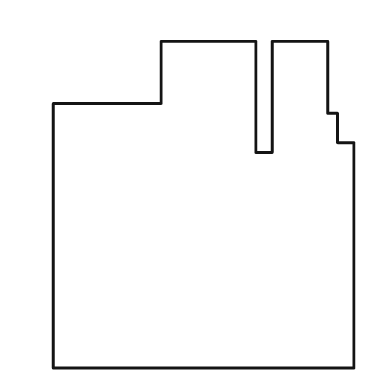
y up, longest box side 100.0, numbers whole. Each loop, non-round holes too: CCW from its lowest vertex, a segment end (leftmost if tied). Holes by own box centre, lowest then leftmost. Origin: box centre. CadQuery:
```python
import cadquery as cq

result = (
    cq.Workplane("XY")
    .moveTo(-46.0, -50.0)
    .lineTo(46.0, -50.0)
    .lineTo(46.0, 19.0)
    .lineTo(41.0, 19.0)
    .lineTo(41.0, 28.0)
    .lineTo(38.0, 28.0)
    .lineTo(38.0, 50.0)
    .lineTo(21.0, 50.0)
    .lineTo(21.0, 16.0)
    .lineTo(16.0, 16.0)
    .lineTo(16.0, 50.0)
    .lineTo(-13.0, 50.0)
    .lineTo(-13.0, 31.0)
    .lineTo(-46.0, 31.0)
    .close()
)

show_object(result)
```